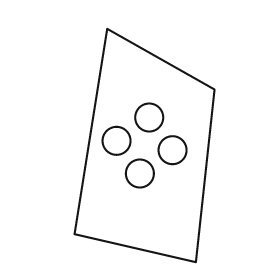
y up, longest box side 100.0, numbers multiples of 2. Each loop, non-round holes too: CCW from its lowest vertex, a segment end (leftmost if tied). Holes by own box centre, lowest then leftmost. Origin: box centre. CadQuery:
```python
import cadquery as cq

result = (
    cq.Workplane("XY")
    .moveTo(22.0, -50.0)
    .lineTo(30.0, 24.0)
    .lineTo(-16.0, 50.0)
    .lineTo(-30.0, -38.0)
    .close()
    .moveTo(-2.0, -12.0)
    .circle(6.0)
    .moveTo(12.0, -2.0)
    .circle(6.0)
    .moveTo(-12.0, 2.0)
    .circle(6.0)
    .moveTo(2.0, 12.0)
    .circle(6.0)
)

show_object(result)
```